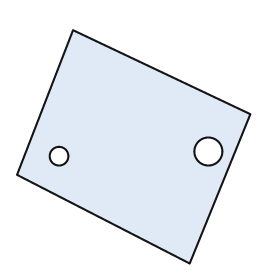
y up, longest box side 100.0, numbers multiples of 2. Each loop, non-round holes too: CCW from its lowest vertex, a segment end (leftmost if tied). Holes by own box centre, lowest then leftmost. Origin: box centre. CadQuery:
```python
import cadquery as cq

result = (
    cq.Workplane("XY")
    .moveTo(24.0, -50.0)
    .lineTo(50.0, 14.0)
    .lineTo(-26.0, 50.0)
    .lineTo(-50.0, -12.0)
    .close()
    .moveTo(-32.0, -4.0)
    .circle(4.0)
    .moveTo(32.0, -2.0)
    .circle(6.0)
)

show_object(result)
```